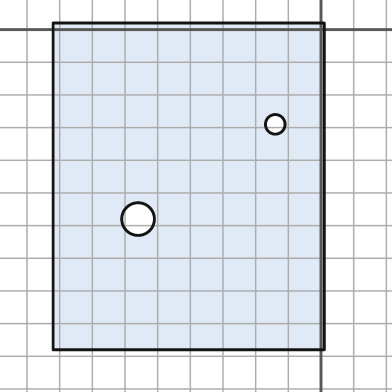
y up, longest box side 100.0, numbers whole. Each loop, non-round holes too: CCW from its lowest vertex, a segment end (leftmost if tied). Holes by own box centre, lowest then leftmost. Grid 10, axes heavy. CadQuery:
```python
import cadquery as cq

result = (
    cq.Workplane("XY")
    .moveTo(-82.0, -98.0)
    .lineTo(1.0, -98.0)
    .lineTo(1.0, 2.0)
    .lineTo(-82.0, 2.0)
    .close()
    .moveTo(-56.0, -58.0)
    .circle(5.0)
    .moveTo(-14.0, -29.0)
    .circle(3.0)
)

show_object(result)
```